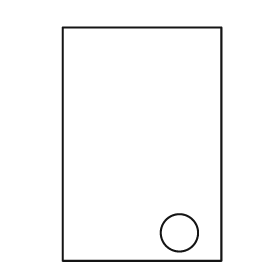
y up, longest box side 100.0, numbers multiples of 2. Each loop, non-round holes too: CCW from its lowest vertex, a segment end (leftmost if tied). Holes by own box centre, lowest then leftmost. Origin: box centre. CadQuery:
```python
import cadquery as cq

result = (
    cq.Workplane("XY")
    .moveTo(-34.0, -50.0)
    .lineTo(34.0, -50.0)
    .lineTo(34.0, 50.0)
    .lineTo(-34.0, 50.0)
    .close()
    .moveTo(16.0, -38.0)
    .circle(8.0)
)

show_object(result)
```